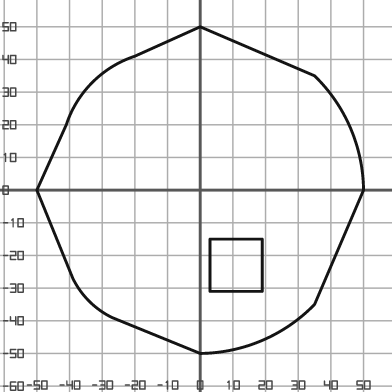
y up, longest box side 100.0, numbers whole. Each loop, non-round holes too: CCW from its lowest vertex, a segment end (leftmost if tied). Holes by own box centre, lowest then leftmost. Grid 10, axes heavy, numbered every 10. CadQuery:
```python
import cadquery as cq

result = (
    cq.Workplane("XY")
    .moveTo(0.0, -50.0)
    .threePointArc((19.0, -46.0), (35.0, -35.0))
    .lineTo(50.0, 0.0)
    .threePointArc((46.0, 19.0), (35.0, 35.0))
    .lineTo(0.0, 50.0)
    .lineTo(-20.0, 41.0)
    .threePointArc((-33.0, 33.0), (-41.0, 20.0))
    .lineTo(-50.0, 0.0)
    .lineTo(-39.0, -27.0)
    .threePointArc((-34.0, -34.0), (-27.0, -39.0))
    .close()
    .moveTo(3.0, -31.0)
    .lineTo(19.0, -31.0)
    .lineTo(19.0, -15.0)
    .lineTo(3.0, -15.0)
    .close()
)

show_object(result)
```